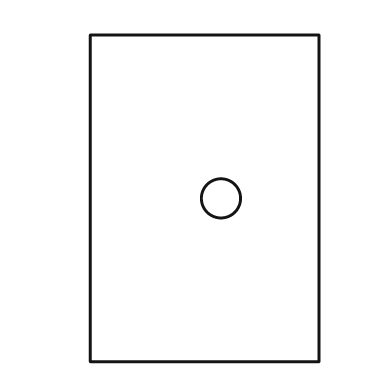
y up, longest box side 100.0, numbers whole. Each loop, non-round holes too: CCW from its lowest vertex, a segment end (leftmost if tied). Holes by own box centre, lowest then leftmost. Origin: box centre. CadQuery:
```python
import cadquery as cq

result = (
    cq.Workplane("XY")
    .moveTo(-35.0, -50.0)
    .lineTo(35.0, -50.0)
    .lineTo(35.0, 50.0)
    .lineTo(-35.0, 50.0)
    .close()
    .moveTo(5.0, 0.0)
    .circle(6.0)
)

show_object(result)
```